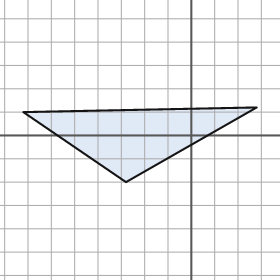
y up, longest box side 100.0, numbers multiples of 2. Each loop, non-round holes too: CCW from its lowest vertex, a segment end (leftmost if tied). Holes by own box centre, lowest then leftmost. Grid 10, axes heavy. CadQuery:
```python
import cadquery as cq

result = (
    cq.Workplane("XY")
    .moveTo(-28.0, -20.0)
    .lineTo(28.0, 12.0)
    .lineTo(-72.0, 10.0)
    .close()
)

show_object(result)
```